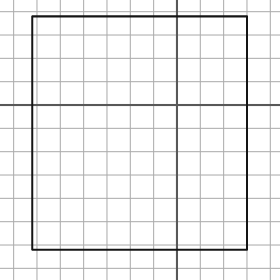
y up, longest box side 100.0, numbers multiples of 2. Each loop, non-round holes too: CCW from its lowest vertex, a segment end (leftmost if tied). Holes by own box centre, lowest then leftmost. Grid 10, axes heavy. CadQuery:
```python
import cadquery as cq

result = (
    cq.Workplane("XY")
    .moveTo(-62.0, -62.0)
    .lineTo(30.0, -62.0)
    .lineTo(30.0, 38.0)
    .lineTo(-62.0, 38.0)
    .close()
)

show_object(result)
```